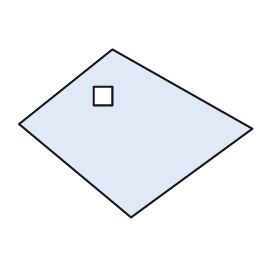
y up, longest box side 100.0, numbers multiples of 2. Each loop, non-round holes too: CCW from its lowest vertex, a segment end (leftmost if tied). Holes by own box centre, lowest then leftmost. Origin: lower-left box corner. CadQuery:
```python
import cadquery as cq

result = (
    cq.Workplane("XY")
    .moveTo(48.0, 0.0)
    .lineTo(100.0, 38.0)
    .lineTo(40.0, 72.0)
    .lineTo(0.0, 40.0)
    .close()
    .moveTo(32.0, 48.0)
    .lineTo(40.0, 48.0)
    .lineTo(40.0, 56.0)
    .lineTo(32.0, 56.0)
    .close()
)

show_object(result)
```